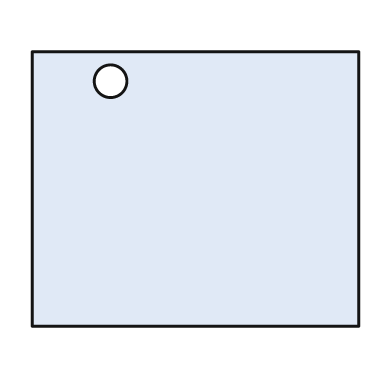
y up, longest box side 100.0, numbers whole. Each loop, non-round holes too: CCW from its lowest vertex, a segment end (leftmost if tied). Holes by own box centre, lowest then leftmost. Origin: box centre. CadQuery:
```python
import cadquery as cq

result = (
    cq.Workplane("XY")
    .moveTo(-50.0, -42.0)
    .lineTo(50.0, -42.0)
    .lineTo(50.0, 42.0)
    .lineTo(-50.0, 42.0)
    .close()
    .moveTo(-26.0, 33.0)
    .circle(5.0)
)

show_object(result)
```